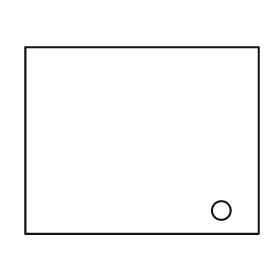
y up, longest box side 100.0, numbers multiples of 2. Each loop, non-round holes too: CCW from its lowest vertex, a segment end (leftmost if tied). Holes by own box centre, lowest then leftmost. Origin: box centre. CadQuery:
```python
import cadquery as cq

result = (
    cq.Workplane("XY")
    .moveTo(-50.0, -40.0)
    .lineTo(50.0, -40.0)
    .lineTo(50.0, 40.0)
    .lineTo(-50.0, 40.0)
    .close()
    .moveTo(34.0, -30.0)
    .circle(4.0)
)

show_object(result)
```